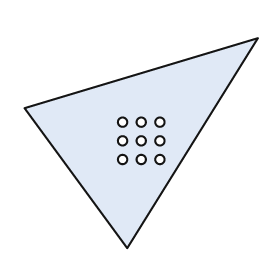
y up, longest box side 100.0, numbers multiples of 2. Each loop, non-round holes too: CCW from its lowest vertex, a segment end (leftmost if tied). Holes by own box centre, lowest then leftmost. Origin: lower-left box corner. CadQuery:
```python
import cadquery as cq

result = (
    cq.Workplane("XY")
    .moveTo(44.0, 0.0)
    .lineTo(100.0, 90.0)
    .lineTo(0.0, 60.0)
    .close()
    .moveTo(42.0, 38.0)
    .circle(2.0)
    .moveTo(50.0, 38.0)
    .circle(2.0)
    .moveTo(58.0, 38.0)
    .circle(2.0)
    .moveTo(42.0, 46.0)
    .circle(2.0)
    .moveTo(50.0, 46.0)
    .circle(2.0)
    .moveTo(58.0, 46.0)
    .circle(2.0)
    .moveTo(42.0, 54.0)
    .circle(2.0)
    .moveTo(50.0, 54.0)
    .circle(2.0)
    .moveTo(58.0, 54.0)
    .circle(2.0)
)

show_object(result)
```